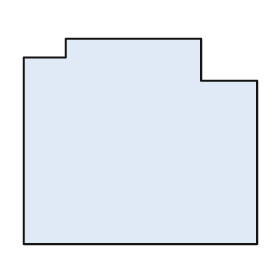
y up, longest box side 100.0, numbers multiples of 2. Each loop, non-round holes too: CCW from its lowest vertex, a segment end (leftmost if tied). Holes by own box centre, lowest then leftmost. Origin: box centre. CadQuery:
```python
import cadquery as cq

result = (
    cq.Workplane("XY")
    .moveTo(-50.0, -44.0)
    .lineTo(50.0, -44.0)
    .lineTo(50.0, 26.0)
    .lineTo(26.0, 26.0)
    .lineTo(26.0, 44.0)
    .lineTo(-32.0, 44.0)
    .lineTo(-32.0, 36.0)
    .lineTo(-50.0, 36.0)
    .close()
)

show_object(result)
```